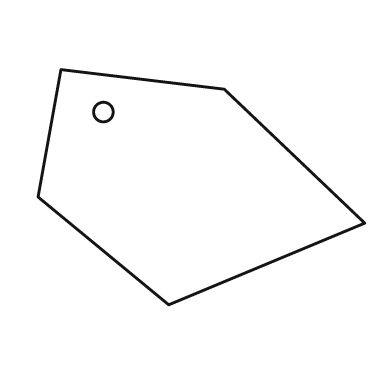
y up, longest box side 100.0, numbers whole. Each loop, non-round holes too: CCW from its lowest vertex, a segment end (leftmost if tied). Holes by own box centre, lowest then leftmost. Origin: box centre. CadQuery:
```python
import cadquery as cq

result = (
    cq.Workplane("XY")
    .moveTo(-10.0, -36.0)
    .lineTo(50.0, -11.0)
    .lineTo(7.0, 30.0)
    .lineTo(-43.0, 36.0)
    .lineTo(-50.0, -3.0)
    .close()
    .moveTo(-30.0, 23.0)
    .circle(3.0)
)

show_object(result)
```